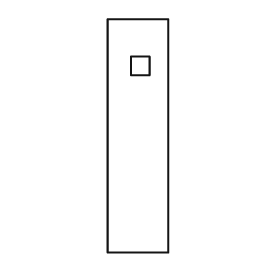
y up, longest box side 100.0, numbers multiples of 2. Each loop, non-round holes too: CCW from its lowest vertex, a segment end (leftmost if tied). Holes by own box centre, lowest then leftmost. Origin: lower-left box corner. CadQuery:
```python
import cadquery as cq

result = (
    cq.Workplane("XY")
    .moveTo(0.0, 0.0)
    .lineTo(26.0, 0.0)
    .lineTo(26.0, 100.0)
    .lineTo(0.0, 100.0)
    .close()
    .moveTo(10.0, 76.0)
    .lineTo(18.0, 76.0)
    .lineTo(18.0, 84.0)
    .lineTo(10.0, 84.0)
    .close()
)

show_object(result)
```